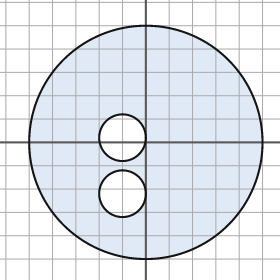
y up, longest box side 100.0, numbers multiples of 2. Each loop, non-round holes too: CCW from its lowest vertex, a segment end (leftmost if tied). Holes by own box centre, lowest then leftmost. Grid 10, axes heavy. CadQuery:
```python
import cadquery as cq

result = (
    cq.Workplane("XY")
    .moveTo(0.0, 0.0)
    .circle(50.0)
    .moveTo(-10.0, -22.0)
    .circle(10.0)
    .moveTo(-10.0, 2.0)
    .circle(10.0)
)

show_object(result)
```